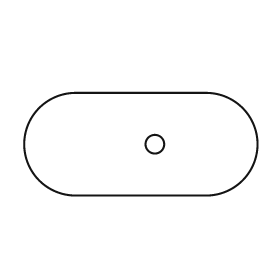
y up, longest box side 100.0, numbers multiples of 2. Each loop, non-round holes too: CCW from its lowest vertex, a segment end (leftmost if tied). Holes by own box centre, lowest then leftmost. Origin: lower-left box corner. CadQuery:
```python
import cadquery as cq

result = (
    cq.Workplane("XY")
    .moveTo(22.0, 0.0)
    .lineTo(78.0, 0.0)
    .threePointArc((100.0, 22.0), (78.0, 44.0))
    .lineTo(22.0, 44.0)
    .threePointArc((0.0, 22.0), (22.0, 0.0))
    .close()
    .moveTo(56.0, 22.0)
    .circle(4.0)
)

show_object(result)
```